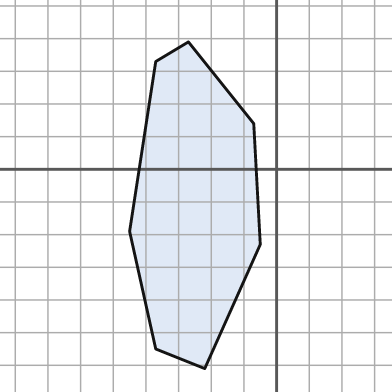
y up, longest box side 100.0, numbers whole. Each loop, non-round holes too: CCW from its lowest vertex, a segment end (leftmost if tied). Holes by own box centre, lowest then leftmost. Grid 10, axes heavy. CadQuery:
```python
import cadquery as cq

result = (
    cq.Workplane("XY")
    .moveTo(-22.0, -61.0)
    .lineTo(-5.0, -23.0)
    .lineTo(-7.0, 14.0)
    .lineTo(-27.0, 39.0)
    .lineTo(-37.0, 33.0)
    .lineTo(-45.0, -19.0)
    .lineTo(-37.0, -55.0)
    .close()
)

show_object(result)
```